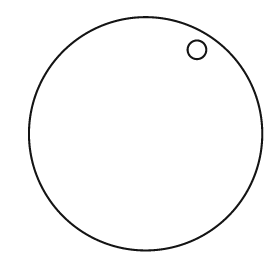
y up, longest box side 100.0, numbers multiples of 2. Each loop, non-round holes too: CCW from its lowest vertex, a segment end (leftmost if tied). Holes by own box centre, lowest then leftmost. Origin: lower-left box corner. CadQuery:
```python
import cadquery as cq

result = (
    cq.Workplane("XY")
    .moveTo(50.0, 50.0)
    .circle(50.0)
    .moveTo(72.0, 86.0)
    .circle(4.0)
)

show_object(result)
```